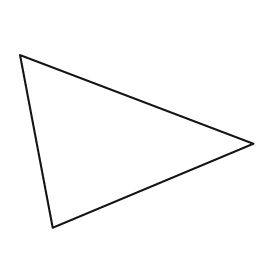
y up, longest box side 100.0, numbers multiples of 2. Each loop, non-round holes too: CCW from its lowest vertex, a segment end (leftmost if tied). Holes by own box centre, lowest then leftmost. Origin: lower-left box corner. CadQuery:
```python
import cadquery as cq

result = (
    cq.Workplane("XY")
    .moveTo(14.0, 0.0)
    .lineTo(100.0, 36.0)
    .lineTo(0.0, 74.0)
    .close()
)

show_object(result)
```